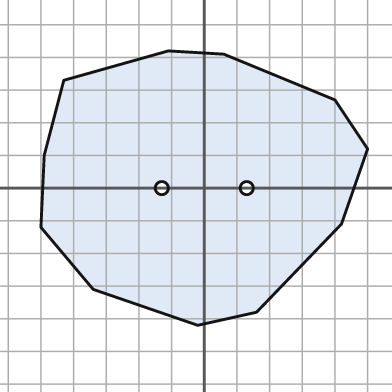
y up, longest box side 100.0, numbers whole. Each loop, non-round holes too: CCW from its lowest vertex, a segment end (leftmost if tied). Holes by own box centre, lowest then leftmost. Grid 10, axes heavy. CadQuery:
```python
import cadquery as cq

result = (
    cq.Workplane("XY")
    .moveTo(-2.0, -42.0)
    .lineTo(16.0, -38.0)
    .lineTo(42.0, -11.0)
    .lineTo(50.0, 12.0)
    .lineTo(40.0, 27.0)
    .lineTo(6.0, 41.0)
    .lineTo(-11.0, 42.0)
    .lineTo(-43.0, 33.0)
    .lineTo(-49.0, 10.0)
    .lineTo(-50.0, -12.0)
    .lineTo(-34.0, -31.0)
    .close()
    .moveTo(-13.0, 0.0)
    .circle(2.0)
    .moveTo(13.0, 0.0)
    .circle(2.0)
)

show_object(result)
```